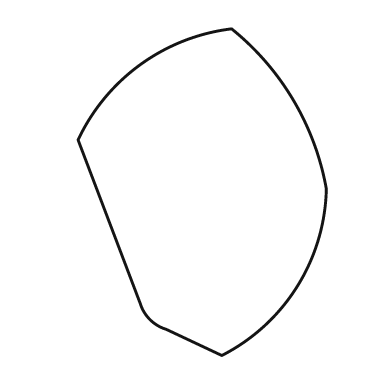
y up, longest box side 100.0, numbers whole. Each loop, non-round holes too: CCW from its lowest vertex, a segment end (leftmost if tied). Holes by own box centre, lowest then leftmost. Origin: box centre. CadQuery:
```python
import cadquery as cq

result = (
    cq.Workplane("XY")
    .moveTo(6.0, -50.0)
    .threePointArc((29.0, -29.0), (38.0, 1.0))
    .threePointArc((28.0, 28.0), (9.0, 50.0))
    .threePointArc((-19.0, 39.0), (-38.0, 16.0))
    .lineTo(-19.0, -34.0)
    .threePointArc((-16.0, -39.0), (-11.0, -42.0))
    .close()
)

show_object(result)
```